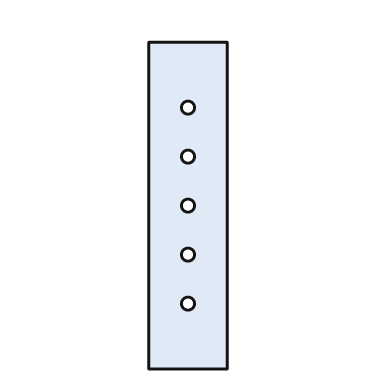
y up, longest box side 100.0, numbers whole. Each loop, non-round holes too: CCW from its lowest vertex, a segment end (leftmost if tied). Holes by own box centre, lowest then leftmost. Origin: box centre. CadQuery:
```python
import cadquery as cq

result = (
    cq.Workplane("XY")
    .moveTo(-12.0, -50.0)
    .lineTo(12.0, -50.0)
    .lineTo(12.0, 50.0)
    .lineTo(-12.0, 50.0)
    .close()
    .moveTo(0.0, -30.0)
    .circle(2.0)
    .moveTo(0.0, -15.0)
    .circle(2.0)
    .moveTo(0.0, 0.0)
    .circle(2.0)
    .moveTo(0.0, 15.0)
    .circle(2.0)
    .moveTo(0.0, 30.0)
    .circle(2.0)
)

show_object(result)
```